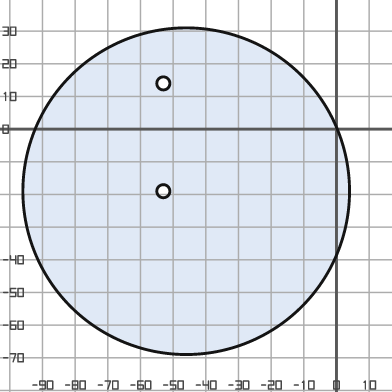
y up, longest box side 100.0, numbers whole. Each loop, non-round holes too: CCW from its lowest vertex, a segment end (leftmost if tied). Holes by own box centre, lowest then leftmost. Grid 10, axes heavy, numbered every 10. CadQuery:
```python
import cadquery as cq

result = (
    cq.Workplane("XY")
    .moveTo(-46.0, -19.0)
    .circle(50.0)
    .moveTo(-53.0, -19.0)
    .circle(2.0)
    .moveTo(-53.0, 14.0)
    .circle(2.0)
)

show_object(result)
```